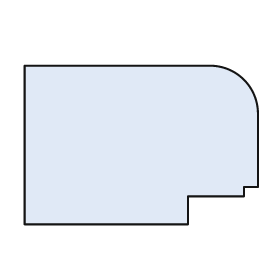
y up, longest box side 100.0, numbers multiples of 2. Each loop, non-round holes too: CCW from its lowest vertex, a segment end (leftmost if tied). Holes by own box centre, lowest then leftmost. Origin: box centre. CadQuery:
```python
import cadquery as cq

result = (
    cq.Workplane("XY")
    .moveTo(-50.0, -34.0)
    .lineTo(20.0, -34.0)
    .lineTo(20.0, -22.0)
    .lineTo(44.0, -22.0)
    .lineTo(44.0, -18.0)
    .lineTo(50.0, -18.0)
    .lineTo(50.0, 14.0)
    .threePointArc((44.0, 28.0), (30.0, 34.0))
    .lineTo(-50.0, 34.0)
    .close()
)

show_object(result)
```